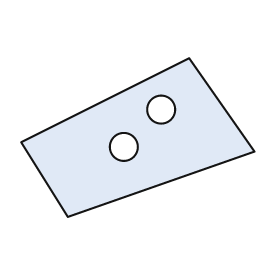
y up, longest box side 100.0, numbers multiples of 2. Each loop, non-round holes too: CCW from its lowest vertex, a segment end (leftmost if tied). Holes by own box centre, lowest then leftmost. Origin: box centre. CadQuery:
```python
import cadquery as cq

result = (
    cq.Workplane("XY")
    .moveTo(-30.0, -34.0)
    .lineTo(50.0, -6.0)
    .lineTo(22.0, 34.0)
    .lineTo(-50.0, -2.0)
    .close()
    .moveTo(-6.0, -4.0)
    .circle(6.0)
    .moveTo(10.0, 12.0)
    .circle(6.0)
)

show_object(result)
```